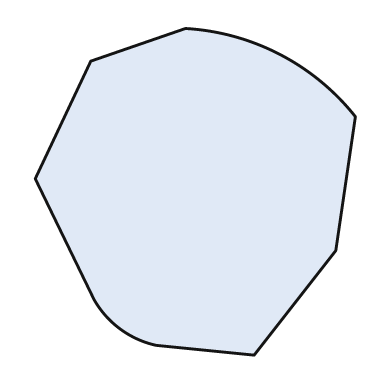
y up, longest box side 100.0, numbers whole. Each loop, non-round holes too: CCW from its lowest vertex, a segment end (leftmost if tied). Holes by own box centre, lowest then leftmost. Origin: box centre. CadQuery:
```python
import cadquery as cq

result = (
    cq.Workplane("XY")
    .moveTo(18.0, -50.0)
    .lineTo(43.0, -18.0)
    .lineTo(49.0, 23.0)
    .threePointArc((26.0, 42.0), (-3.0, 50.0))
    .lineTo(-32.0, 40.0)
    .lineTo(-49.0, 4.0)
    .lineTo(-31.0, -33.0)
    .threePointArc((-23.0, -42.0), (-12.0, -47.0))
    .close()
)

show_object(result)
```